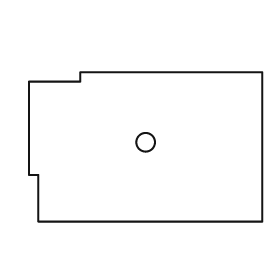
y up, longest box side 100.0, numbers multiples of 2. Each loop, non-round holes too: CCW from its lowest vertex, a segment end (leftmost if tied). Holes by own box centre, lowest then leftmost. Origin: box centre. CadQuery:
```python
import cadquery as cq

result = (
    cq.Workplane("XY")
    .moveTo(-46.0, -32.0)
    .lineTo(50.0, -32.0)
    .lineTo(50.0, 32.0)
    .lineTo(-28.0, 32.0)
    .lineTo(-28.0, 28.0)
    .lineTo(-50.0, 28.0)
    .lineTo(-50.0, -12.0)
    .lineTo(-46.0, -12.0)
    .close()
    .moveTo(0.0, 2.0)
    .circle(4.0)
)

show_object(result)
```